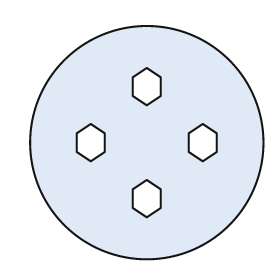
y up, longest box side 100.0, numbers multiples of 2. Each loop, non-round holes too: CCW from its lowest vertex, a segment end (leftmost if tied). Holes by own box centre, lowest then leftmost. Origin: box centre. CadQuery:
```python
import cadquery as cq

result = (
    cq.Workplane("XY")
    .moveTo(0.0, 0.0)
    .circle(50.0)
    .moveTo(0.0, -32.0)
    .lineTo(6.0, -28.0)
    .lineTo(6.0, -20.0)
    .lineTo(0.0, -16.0)
    .lineTo(-6.0, -20.0)
    .lineTo(-6.0, -28.0)
    .close()
    .moveTo(-24.0, -8.0)
    .lineTo(-18.0, -4.0)
    .lineTo(-18.0, 4.0)
    .lineTo(-24.0, 8.0)
    .lineTo(-30.0, 4.0)
    .lineTo(-30.0, -4.0)
    .close()
    .moveTo(24.0, -8.0)
    .lineTo(30.0, -4.0)
    .lineTo(30.0, 4.0)
    .lineTo(24.0, 8.0)
    .lineTo(18.0, 4.0)
    .lineTo(18.0, -4.0)
    .close()
    .moveTo(0.0, 16.0)
    .lineTo(6.0, 20.0)
    .lineTo(6.0, 28.0)
    .lineTo(0.0, 32.0)
    .lineTo(-6.0, 28.0)
    .lineTo(-6.0, 20.0)
    .close()
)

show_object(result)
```